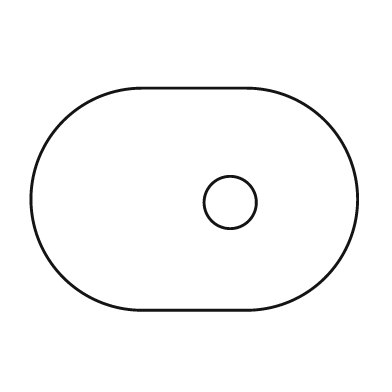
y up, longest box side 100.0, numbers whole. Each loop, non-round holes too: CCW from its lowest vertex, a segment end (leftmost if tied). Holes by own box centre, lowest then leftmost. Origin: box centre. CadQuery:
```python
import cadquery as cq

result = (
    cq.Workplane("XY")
    .moveTo(-16.0, -34.0)
    .lineTo(16.0, -34.0)
    .threePointArc((50.0, 0.0), (16.0, 34.0))
    .lineTo(-16.0, 34.0)
    .threePointArc((-50.0, 0.0), (-16.0, -34.0))
    .close()
    .moveTo(11.0, -1.0)
    .circle(8.0)
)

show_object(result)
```